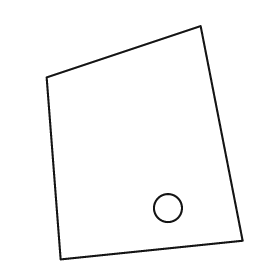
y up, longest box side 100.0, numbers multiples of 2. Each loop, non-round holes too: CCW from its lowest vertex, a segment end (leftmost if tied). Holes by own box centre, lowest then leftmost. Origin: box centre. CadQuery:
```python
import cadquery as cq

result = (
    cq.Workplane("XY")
    .moveTo(-36.0, -50.0)
    .lineTo(42.0, -42.0)
    .lineTo(24.0, 50.0)
    .lineTo(-42.0, 28.0)
    .close()
    .moveTo(10.0, -28.0)
    .circle(6.0)
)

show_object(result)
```